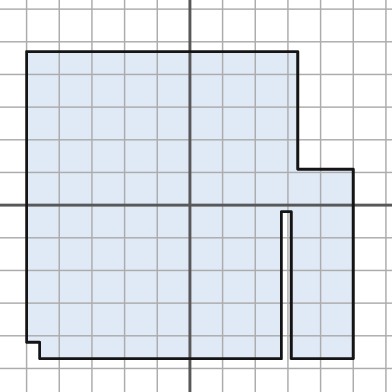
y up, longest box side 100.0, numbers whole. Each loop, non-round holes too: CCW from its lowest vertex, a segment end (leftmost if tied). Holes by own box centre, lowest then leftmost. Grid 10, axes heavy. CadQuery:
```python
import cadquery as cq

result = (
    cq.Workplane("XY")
    .moveTo(-46.0, -47.0)
    .lineTo(28.0, -47.0)
    .lineTo(28.0, -2.0)
    .lineTo(31.0, -2.0)
    .lineTo(31.0, -47.0)
    .lineTo(50.0, -47.0)
    .lineTo(50.0, 11.0)
    .lineTo(33.0, 11.0)
    .lineTo(33.0, 47.0)
    .lineTo(-50.0, 47.0)
    .lineTo(-50.0, -42.0)
    .lineTo(-46.0, -42.0)
    .close()
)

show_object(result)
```